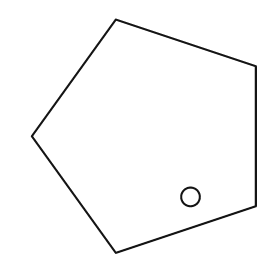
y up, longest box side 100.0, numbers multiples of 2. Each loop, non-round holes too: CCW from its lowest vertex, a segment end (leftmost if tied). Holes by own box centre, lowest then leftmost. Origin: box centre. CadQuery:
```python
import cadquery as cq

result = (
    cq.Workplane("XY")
    .moveTo(-12.0, -50.0)
    .lineTo(48.0, -30.0)
    .lineTo(48.0, 30.0)
    .lineTo(-12.0, 50.0)
    .lineTo(-48.0, 0.0)
    .close()
    .moveTo(20.0, -26.0)
    .circle(4.0)
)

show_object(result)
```